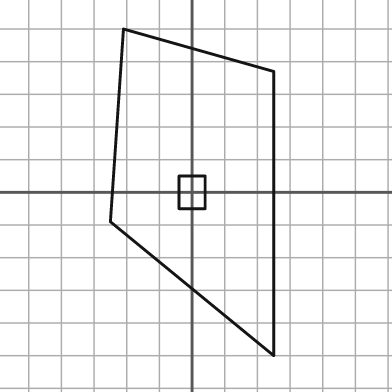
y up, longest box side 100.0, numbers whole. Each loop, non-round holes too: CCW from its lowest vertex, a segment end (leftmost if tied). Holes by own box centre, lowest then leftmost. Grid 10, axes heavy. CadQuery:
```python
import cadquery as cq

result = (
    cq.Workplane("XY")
    .moveTo(25.0, -50.0)
    .lineTo(25.0, 37.0)
    .lineTo(-21.0, 50.0)
    .lineTo(-25.0, -9.0)
    .close()
    .moveTo(-4.0, -5.0)
    .lineTo(4.0, -5.0)
    .lineTo(4.0, 5.0)
    .lineTo(-4.0, 5.0)
    .close()
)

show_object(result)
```